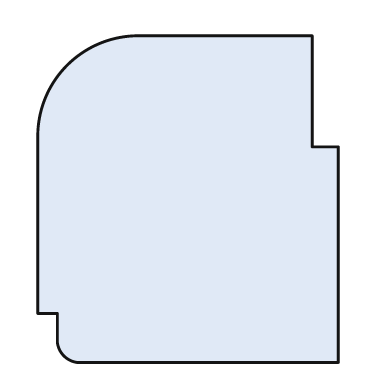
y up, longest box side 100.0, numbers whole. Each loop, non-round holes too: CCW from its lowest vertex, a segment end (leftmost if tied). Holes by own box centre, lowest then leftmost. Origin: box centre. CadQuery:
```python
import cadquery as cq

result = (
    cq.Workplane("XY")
    .moveTo(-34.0, -50.0)
    .lineTo(46.0, -50.0)
    .lineTo(46.0, 16.0)
    .lineTo(38.0, 16.0)
    .lineTo(38.0, 50.0)
    .lineTo(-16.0, 50.0)
    .threePointArc((-37.0, 41.0), (-46.0, 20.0))
    .lineTo(-46.0, -35.0)
    .lineTo(-40.0, -35.0)
    .lineTo(-40.0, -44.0)
    .threePointArc((-38.0, -48.0), (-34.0, -50.0))
    .close()
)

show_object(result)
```